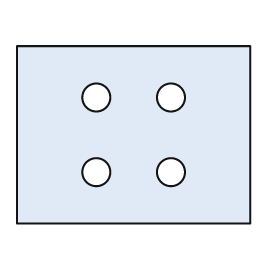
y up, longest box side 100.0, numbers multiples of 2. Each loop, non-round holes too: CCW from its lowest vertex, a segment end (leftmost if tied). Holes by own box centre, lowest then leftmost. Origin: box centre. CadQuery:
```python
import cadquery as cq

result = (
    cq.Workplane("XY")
    .moveTo(-50.0, -38.0)
    .lineTo(50.0, -38.0)
    .lineTo(50.0, 38.0)
    .lineTo(-50.0, 38.0)
    .close()
    .moveTo(-16.0, -16.0)
    .circle(6.0)
    .moveTo(16.0, -16.0)
    .circle(6.0)
    .moveTo(-16.0, 16.0)
    .circle(6.0)
    .moveTo(16.0, 16.0)
    .circle(6.0)
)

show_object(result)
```